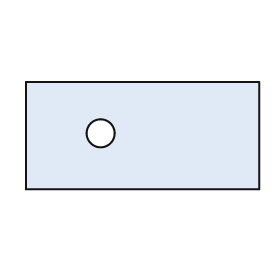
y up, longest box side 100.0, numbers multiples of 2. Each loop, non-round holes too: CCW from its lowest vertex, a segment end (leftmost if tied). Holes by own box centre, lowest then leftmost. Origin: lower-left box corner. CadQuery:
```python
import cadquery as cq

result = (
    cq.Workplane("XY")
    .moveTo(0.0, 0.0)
    .lineTo(100.0, 0.0)
    .lineTo(100.0, 46.0)
    .lineTo(0.0, 46.0)
    .close()
    .moveTo(32.0, 24.0)
    .circle(6.0)
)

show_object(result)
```